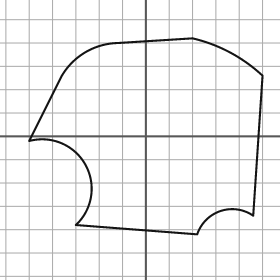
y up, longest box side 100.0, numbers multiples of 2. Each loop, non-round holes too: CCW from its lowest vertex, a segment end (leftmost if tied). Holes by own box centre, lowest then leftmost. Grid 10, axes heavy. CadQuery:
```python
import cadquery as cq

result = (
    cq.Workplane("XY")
    .moveTo(22.0, -42.0)
    .threePointArc((32.0, -32.0), (46.0, -34.0))
    .lineTo(50.0, 26.0)
    .threePointArc((36.0, 36.0), (20.0, 42.0))
    .lineTo(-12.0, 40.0)
    .threePointArc((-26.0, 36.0), (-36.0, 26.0))
    .lineTo(-50.0, -2.0)
    .threePointArc((-26.0, -12.0), (-30.0, -38.0))
    .close()
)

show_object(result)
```